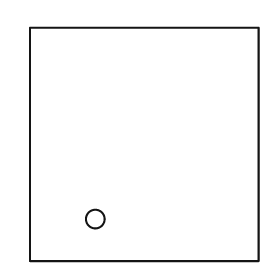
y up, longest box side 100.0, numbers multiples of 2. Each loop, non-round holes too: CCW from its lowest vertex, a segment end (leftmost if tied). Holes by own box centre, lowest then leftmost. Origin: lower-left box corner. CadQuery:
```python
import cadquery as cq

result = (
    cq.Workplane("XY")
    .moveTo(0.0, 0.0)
    .lineTo(98.0, 0.0)
    .lineTo(98.0, 100.0)
    .lineTo(0.0, 100.0)
    .close()
    .moveTo(28.0, 18.0)
    .circle(4.0)
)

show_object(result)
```